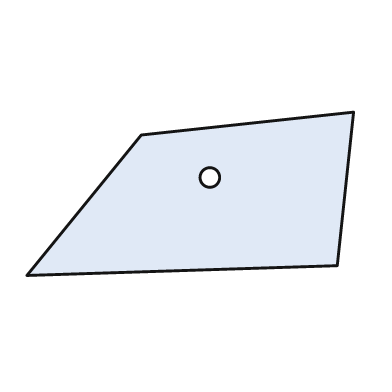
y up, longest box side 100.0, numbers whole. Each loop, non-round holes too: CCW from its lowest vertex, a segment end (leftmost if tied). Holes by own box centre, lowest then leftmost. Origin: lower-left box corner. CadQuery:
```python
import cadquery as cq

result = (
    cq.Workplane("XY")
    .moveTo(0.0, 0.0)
    .lineTo(95.0, 3.0)
    .lineTo(100.0, 50.0)
    .lineTo(35.0, 43.0)
    .close()
    .moveTo(56.0, 30.0)
    .circle(3.0)
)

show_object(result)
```